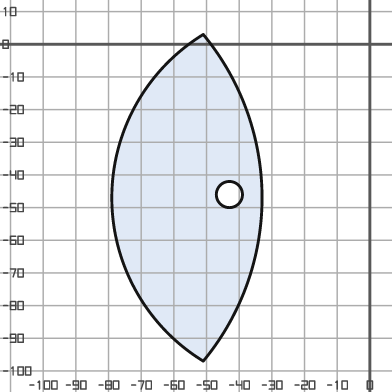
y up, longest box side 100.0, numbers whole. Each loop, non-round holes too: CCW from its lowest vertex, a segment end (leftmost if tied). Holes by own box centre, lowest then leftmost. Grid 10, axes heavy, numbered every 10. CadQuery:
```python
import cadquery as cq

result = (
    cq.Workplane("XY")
    .moveTo(-51.0, -97.0)
    .threePointArc((-33.0, -47.0), (-51.0, 3.0))
    .threePointArc((-79.0, -47.0), (-51.0, -97.0))
    .close()
    .moveTo(-43.0, -46.0)
    .circle(4.0)
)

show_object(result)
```